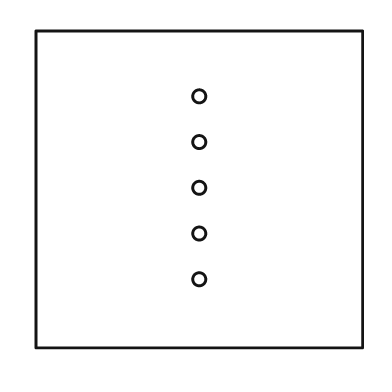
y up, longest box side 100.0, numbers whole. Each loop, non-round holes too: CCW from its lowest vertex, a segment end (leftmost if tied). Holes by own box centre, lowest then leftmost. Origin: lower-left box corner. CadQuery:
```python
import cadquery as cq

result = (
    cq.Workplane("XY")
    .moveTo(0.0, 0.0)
    .lineTo(100.0, 0.0)
    .lineTo(100.0, 97.0)
    .lineTo(0.0, 97.0)
    .close()
    .moveTo(50.0, 21.0)
    .circle(2.0)
    .moveTo(50.0, 35.0)
    .circle(2.0)
    .moveTo(50.0, 49.0)
    .circle(2.0)
    .moveTo(50.0, 63.0)
    .circle(2.0)
    .moveTo(50.0, 77.0)
    .circle(2.0)
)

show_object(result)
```